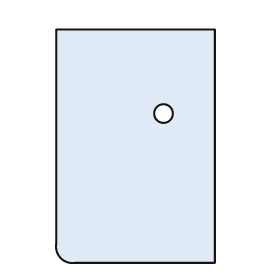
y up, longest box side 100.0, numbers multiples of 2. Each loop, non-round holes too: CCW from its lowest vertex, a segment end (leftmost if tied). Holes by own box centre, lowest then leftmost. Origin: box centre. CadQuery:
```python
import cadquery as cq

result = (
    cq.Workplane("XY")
    .moveTo(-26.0, -50.0)
    .lineTo(34.0, -50.0)
    .lineTo(34.0, 50.0)
    .lineTo(-34.0, 50.0)
    .lineTo(-34.0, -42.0)
    .threePointArc((-32.0, -48.0), (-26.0, -50.0))
    .close()
    .moveTo(12.0, 14.0)
    .circle(4.0)
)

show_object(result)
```